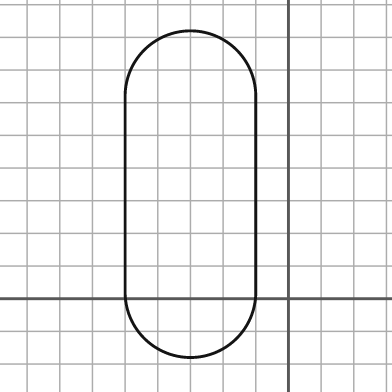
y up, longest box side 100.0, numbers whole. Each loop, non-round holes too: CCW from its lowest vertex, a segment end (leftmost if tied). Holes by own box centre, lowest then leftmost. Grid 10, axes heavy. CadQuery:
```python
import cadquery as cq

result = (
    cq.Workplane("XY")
    .moveTo(-50.0, 2.0)
    .threePointArc((-30.0, -18.0), (-10.0, 2.0))
    .lineTo(-10.0, 62.0)
    .threePointArc((-30.0, 82.0), (-50.0, 62.0))
    .close()
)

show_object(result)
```